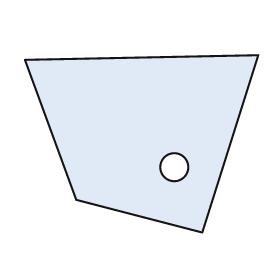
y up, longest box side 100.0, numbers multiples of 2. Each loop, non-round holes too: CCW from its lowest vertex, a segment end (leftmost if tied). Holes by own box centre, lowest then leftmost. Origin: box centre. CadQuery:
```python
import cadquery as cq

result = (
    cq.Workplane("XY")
    .moveTo(26.0, -38.0)
    .lineTo(50.0, 38.0)
    .lineTo(-50.0, 36.0)
    .lineTo(-28.0, -24.0)
    .close()
    .moveTo(14.0, -10.0)
    .circle(6.0)
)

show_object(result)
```